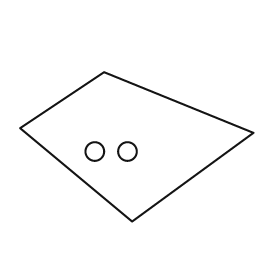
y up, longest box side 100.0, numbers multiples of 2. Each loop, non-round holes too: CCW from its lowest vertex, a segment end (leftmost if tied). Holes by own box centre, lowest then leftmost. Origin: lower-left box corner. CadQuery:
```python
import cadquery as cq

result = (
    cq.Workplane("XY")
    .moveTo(48.0, 0.0)
    .lineTo(100.0, 38.0)
    .lineTo(36.0, 64.0)
    .lineTo(0.0, 40.0)
    .close()
    .moveTo(32.0, 30.0)
    .circle(4.0)
    .moveTo(46.0, 30.0)
    .circle(4.0)
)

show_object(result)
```